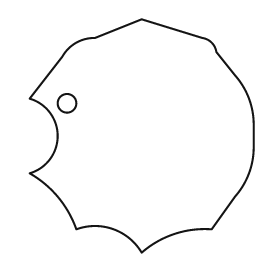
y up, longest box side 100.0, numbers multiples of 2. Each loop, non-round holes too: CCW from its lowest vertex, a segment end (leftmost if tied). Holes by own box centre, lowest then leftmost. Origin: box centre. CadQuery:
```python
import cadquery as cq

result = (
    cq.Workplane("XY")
    .moveTo(0.0, -50.0)
    .threePointArc((14.0, -42.0), (30.0, -40.0))
    .lineTo(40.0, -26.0)
    .threePointArc((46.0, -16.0), (48.0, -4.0))
    .lineTo(48.0, 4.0)
    .threePointArc((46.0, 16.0), (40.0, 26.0))
    .lineTo(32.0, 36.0)
    .threePointArc((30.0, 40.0), (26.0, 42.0))
    .lineTo(0.0, 50.0)
    .lineTo(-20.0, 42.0)
    .threePointArc((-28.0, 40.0), (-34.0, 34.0))
    .lineTo(-48.0, 16.0)
    .threePointArc((-36.0, 0.0), (-48.0, -16.0))
    .threePointArc((-36.0, -26.0), (-28.0, -40.0))
    .threePointArc((-12.0, -40.0), (0.0, -50.0))
    .close()
    .moveTo(-32.0, 14.0)
    .circle(4.0)
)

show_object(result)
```